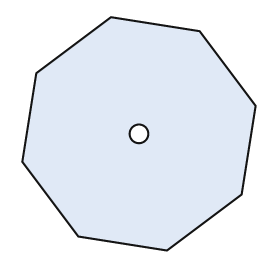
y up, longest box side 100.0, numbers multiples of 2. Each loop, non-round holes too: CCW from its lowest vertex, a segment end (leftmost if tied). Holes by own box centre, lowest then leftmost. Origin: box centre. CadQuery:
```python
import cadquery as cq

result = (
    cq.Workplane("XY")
    .moveTo(12.0, -50.0)
    .lineTo(44.0, -26.0)
    .lineTo(50.0, 12.0)
    .lineTo(26.0, 44.0)
    .lineTo(-12.0, 50.0)
    .lineTo(-44.0, 26.0)
    .lineTo(-50.0, -12.0)
    .lineTo(-26.0, -44.0)
    .close()
    .moveTo(0.0, 0.0)
    .circle(4.0)
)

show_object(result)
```